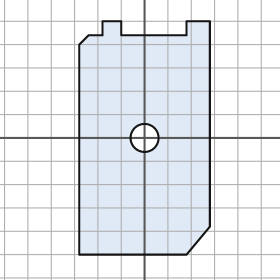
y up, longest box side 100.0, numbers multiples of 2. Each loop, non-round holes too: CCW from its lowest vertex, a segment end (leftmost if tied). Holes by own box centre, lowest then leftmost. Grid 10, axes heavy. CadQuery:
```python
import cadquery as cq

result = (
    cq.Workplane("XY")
    .moveTo(-28.0, -50.0)
    .lineTo(18.0, -50.0)
    .lineTo(28.0, -38.0)
    .lineTo(28.0, 50.0)
    .lineTo(18.0, 50.0)
    .lineTo(18.0, 44.0)
    .lineTo(-10.0, 44.0)
    .lineTo(-10.0, 50.0)
    .lineTo(-18.0, 50.0)
    .lineTo(-18.0, 44.0)
    .lineTo(-24.0, 44.0)
    .lineTo(-28.0, 40.0)
    .close()
    .moveTo(0.0, 0.0)
    .circle(6.0)
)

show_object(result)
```